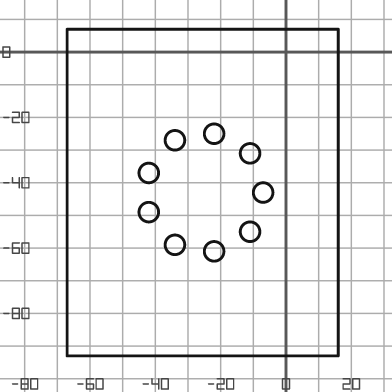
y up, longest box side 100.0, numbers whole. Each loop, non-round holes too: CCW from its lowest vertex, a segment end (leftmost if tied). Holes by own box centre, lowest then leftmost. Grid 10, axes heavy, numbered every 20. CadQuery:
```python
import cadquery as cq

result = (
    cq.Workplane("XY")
    .moveTo(-67.0, -93.0)
    .lineTo(16.0, -93.0)
    .lineTo(16.0, 7.0)
    .lineTo(-67.0, 7.0)
    .close()
    .moveTo(-22.0, -61.0)
    .circle(3.0)
    .moveTo(-34.0, -59.0)
    .circle(3.0)
    .moveTo(-11.0, -55.0)
    .circle(3.0)
    .moveTo(-42.0, -49.0)
    .circle(3.0)
    .moveTo(-7.0, -43.0)
    .circle(3.0)
    .moveTo(-42.0, -37.0)
    .circle(3.0)
    .moveTo(-11.0, -31.0)
    .circle(3.0)
    .moveTo(-34.0, -27.0)
    .circle(3.0)
    .moveTo(-22.0, -25.0)
    .circle(3.0)
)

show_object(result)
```